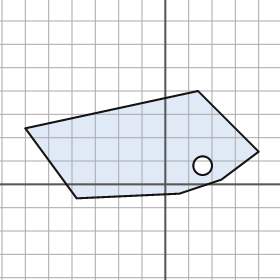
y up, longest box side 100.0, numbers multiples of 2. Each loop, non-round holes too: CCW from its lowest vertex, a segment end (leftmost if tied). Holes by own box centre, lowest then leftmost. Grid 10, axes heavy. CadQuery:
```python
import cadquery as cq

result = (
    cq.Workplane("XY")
    .moveTo(-38.0, -6.0)
    .lineTo(6.0, -4.0)
    .lineTo(24.0, 2.0)
    .lineTo(40.0, 14.0)
    .lineTo(14.0, 40.0)
    .lineTo(-60.0, 24.0)
    .close()
    .moveTo(16.0, 8.0)
    .circle(4.0)
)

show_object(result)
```